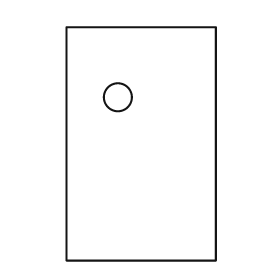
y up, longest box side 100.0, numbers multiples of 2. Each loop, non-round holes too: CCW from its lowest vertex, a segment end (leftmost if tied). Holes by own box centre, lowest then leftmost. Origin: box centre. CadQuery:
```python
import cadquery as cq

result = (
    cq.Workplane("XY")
    .moveTo(-32.0, -50.0)
    .lineTo(32.0, -50.0)
    .lineTo(32.0, 50.0)
    .lineTo(-32.0, 50.0)
    .close()
    .moveTo(-10.0, 20.0)
    .circle(6.0)
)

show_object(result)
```